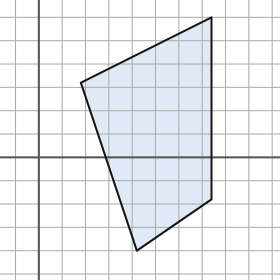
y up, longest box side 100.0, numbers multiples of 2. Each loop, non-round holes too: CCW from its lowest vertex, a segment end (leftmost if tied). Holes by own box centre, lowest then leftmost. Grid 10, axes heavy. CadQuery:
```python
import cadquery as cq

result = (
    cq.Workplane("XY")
    .moveTo(42.0, -40.0)
    .lineTo(74.0, -18.0)
    .lineTo(74.0, 60.0)
    .lineTo(18.0, 32.0)
    .close()
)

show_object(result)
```